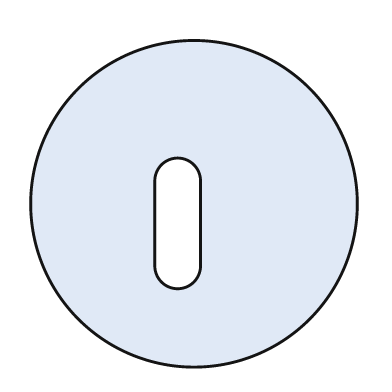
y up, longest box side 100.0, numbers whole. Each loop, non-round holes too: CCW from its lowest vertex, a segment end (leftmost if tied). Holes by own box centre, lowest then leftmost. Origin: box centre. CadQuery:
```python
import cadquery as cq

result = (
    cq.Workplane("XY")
    .moveTo(0.0, 0.0)
    .circle(50.0)
    .moveTo(-12.0, -19.0)
    .threePointArc((-5.0, -26.0), (2.0, -19.0))
    .lineTo(2.0, 7.0)
    .threePointArc((-5.0, 14.0), (-12.0, 7.0))
    .close()
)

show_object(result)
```